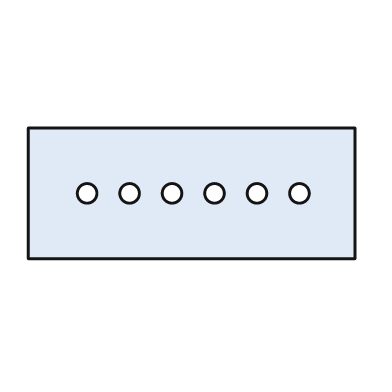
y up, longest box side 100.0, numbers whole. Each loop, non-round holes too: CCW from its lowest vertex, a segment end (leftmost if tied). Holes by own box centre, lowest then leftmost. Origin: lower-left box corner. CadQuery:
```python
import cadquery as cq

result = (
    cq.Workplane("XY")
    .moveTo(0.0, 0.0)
    .lineTo(100.0, 0.0)
    .lineTo(100.0, 40.0)
    .lineTo(0.0, 40.0)
    .close()
    .moveTo(18.0, 20.0)
    .circle(3.0)
    .moveTo(31.0, 20.0)
    .circle(3.0)
    .moveTo(44.0, 20.0)
    .circle(3.0)
    .moveTo(57.0, 20.0)
    .circle(3.0)
    .moveTo(70.0, 20.0)
    .circle(3.0)
    .moveTo(83.0, 20.0)
    .circle(3.0)
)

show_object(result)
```